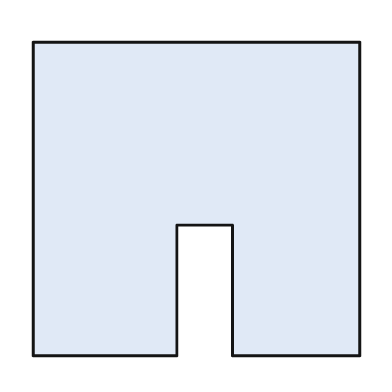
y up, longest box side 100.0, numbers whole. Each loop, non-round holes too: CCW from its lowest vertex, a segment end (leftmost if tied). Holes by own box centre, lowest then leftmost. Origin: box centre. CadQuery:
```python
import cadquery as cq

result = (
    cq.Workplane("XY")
    .moveTo(-50.0, -48.0)
    .lineTo(-6.0, -48.0)
    .lineTo(-6.0, -8.0)
    .lineTo(11.0, -8.0)
    .lineTo(11.0, -48.0)
    .lineTo(50.0, -48.0)
    .lineTo(50.0, 48.0)
    .lineTo(-50.0, 48.0)
    .close()
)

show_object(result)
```